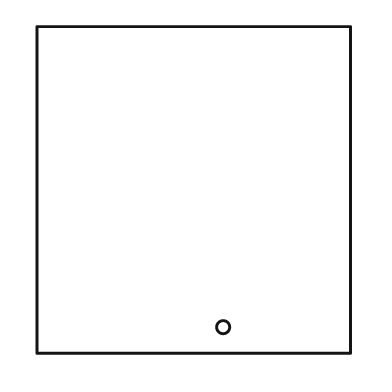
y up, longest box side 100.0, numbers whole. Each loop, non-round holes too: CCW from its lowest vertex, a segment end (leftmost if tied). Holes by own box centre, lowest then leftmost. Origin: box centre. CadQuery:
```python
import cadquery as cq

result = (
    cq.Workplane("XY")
    .moveTo(-48.0, -50.0)
    .lineTo(48.0, -50.0)
    .lineTo(48.0, 50.0)
    .lineTo(-48.0, 50.0)
    .close()
    .moveTo(9.0, -42.0)
    .circle(2.0)
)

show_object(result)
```